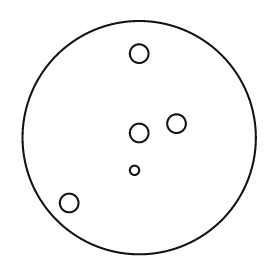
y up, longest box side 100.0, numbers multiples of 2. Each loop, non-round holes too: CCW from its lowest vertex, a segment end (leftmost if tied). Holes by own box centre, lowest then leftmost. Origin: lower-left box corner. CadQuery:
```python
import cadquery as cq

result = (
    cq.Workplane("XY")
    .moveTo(50.0, 50.0)
    .circle(50.0)
    .moveTo(20.0, 22.0)
    .circle(4.0)
    .moveTo(48.0, 36.0)
    .circle(2.0)
    .moveTo(50.0, 52.0)
    .circle(4.0)
    .moveTo(66.0, 56.0)
    .circle(4.0)
    .moveTo(50.0, 86.0)
    .circle(4.0)
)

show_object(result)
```